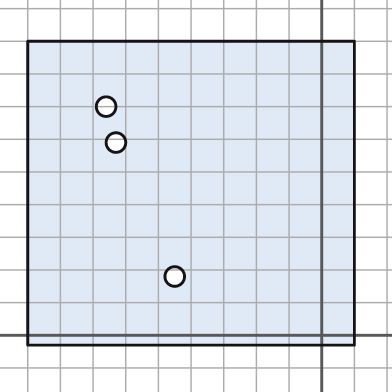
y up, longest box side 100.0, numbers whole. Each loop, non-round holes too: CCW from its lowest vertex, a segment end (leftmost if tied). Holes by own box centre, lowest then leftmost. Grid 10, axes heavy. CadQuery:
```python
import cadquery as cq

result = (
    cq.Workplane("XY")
    .moveTo(-90.0, -3.0)
    .lineTo(10.0, -3.0)
    .lineTo(10.0, 90.0)
    .lineTo(-90.0, 90.0)
    .close()
    .moveTo(-45.0, 18.0)
    .circle(3.0)
    .moveTo(-63.0, 59.0)
    .circle(3.0)
    .moveTo(-66.0, 70.0)
    .circle(3.0)
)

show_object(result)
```